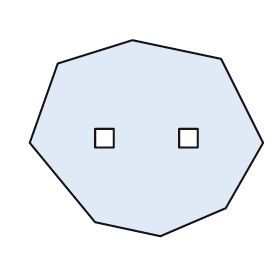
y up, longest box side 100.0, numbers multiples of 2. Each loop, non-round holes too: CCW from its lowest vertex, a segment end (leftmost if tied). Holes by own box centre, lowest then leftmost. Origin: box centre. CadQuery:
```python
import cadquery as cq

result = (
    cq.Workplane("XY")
    .moveTo(6.0, -42.0)
    .lineTo(34.0, -30.0)
    .lineTo(50.0, -2.0)
    .lineTo(32.0, 34.0)
    .lineTo(-6.0, 42.0)
    .lineTo(-38.0, 32.0)
    .lineTo(-50.0, -2.0)
    .lineTo(-22.0, -36.0)
    .close()
    .moveTo(-22.0, -4.0)
    .lineTo(-14.0, -4.0)
    .lineTo(-14.0, 4.0)
    .lineTo(-22.0, 4.0)
    .close()
    .moveTo(14.0, -4.0)
    .lineTo(22.0, -4.0)
    .lineTo(22.0, 4.0)
    .lineTo(14.0, 4.0)
    .close()
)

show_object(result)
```